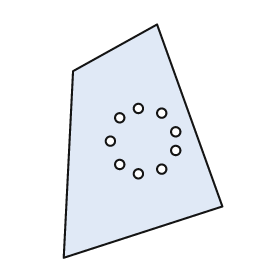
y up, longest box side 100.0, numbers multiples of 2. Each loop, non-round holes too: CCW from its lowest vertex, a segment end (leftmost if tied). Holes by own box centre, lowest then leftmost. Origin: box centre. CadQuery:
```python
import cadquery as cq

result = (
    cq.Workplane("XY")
    .moveTo(-34.0, -50.0)
    .lineTo(34.0, -28.0)
    .lineTo(6.0, 50.0)
    .lineTo(-30.0, 30.0)
    .close()
    .moveTo(-2.0, -14.0)
    .circle(2.0)
    .moveTo(8.0, -12.0)
    .circle(2.0)
    .moveTo(-10.0, -10.0)
    .circle(2.0)
    .moveTo(14.0, -4.0)
    .circle(2.0)
    .moveTo(-14.0, 0.0)
    .circle(2.0)
    .moveTo(14.0, 4.0)
    .circle(2.0)
    .moveTo(-10.0, 10.0)
    .circle(2.0)
    .moveTo(8.0, 12.0)
    .circle(2.0)
    .moveTo(-2.0, 14.0)
    .circle(2.0)
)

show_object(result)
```